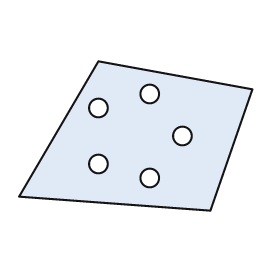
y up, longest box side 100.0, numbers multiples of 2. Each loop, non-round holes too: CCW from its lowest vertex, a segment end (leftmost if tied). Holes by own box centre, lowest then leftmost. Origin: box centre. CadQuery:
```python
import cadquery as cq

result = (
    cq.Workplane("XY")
    .moveTo(32.0, -32.0)
    .lineTo(50.0, 20.0)
    .lineTo(-16.0, 32.0)
    .lineTo(-50.0, -26.0)
    .close()
    .moveTo(6.0, -18.0)
    .circle(4.0)
    .moveTo(-16.0, -12.0)
    .circle(4.0)
    .moveTo(20.0, 0.0)
    .circle(4.0)
    .moveTo(-16.0, 12.0)
    .circle(4.0)
    .moveTo(6.0, 18.0)
    .circle(4.0)
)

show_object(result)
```